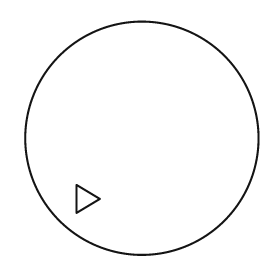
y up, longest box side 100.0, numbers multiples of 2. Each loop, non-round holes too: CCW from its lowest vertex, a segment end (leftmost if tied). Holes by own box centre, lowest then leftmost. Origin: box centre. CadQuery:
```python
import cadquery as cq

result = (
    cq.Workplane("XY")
    .moveTo(0.0, 0.0)
    .circle(50.0)
    .moveTo(-28.0, -32.0)
    .lineTo(-18.0, -26.0)
    .lineTo(-28.0, -20.0)
    .close()
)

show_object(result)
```